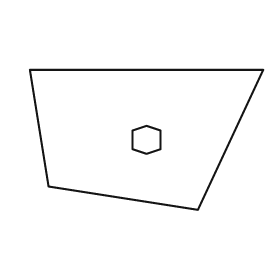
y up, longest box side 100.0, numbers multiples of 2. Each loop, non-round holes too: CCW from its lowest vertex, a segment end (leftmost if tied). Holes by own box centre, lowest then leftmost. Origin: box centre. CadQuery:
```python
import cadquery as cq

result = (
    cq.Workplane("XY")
    .moveTo(22.0, -30.0)
    .lineTo(50.0, 30.0)
    .lineTo(-50.0, 30.0)
    .lineTo(-42.0, -20.0)
    .close()
    .moveTo(0.0, -6.0)
    .lineTo(6.0, -4.0)
    .lineTo(6.0, 4.0)
    .lineTo(0.0, 6.0)
    .lineTo(-6.0, 4.0)
    .lineTo(-6.0, -4.0)
    .close()
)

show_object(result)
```